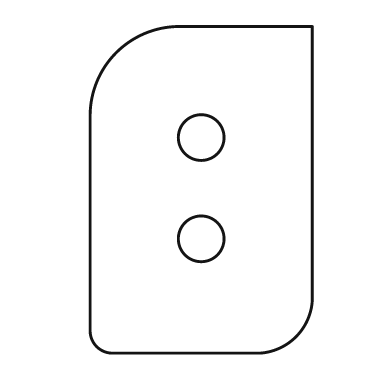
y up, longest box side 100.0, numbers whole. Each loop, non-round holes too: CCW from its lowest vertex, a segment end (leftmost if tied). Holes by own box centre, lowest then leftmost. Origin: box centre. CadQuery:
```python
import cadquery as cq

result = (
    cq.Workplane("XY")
    .moveTo(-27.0, -50.0)
    .lineTo(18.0, -50.0)
    .threePointArc((29.0, -45.0), (34.0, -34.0))
    .lineTo(34.0, 50.0)
    .lineTo(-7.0, 50.0)
    .threePointArc((-26.0, 42.0), (-34.0, 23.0))
    .lineTo(-34.0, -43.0)
    .threePointArc((-32.0, -48.0), (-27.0, -50.0))
    .close()
    .moveTo(0.0, -15.0)
    .circle(7.0)
    .moveTo(0.0, 16.0)
    .circle(7.0)
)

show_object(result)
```